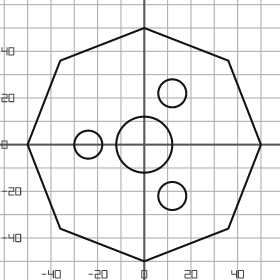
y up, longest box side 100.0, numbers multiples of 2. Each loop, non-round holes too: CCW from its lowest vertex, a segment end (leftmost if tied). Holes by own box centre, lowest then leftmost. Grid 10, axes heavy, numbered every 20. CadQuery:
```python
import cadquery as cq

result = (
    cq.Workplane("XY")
    .moveTo(0.0, -50.0)
    .lineTo(36.0, -36.0)
    .lineTo(50.0, 0.0)
    .lineTo(36.0, 36.0)
    .lineTo(0.0, 50.0)
    .lineTo(-36.0, 36.0)
    .lineTo(-50.0, 0.0)
    .lineTo(-36.0, -36.0)
    .close()
    .moveTo(12.0, -22.0)
    .circle(6.0)
    .moveTo(-24.0, 0.0)
    .circle(6.0)
    .moveTo(0.0, 0.0)
    .circle(12.0)
    .moveTo(12.0, 22.0)
    .circle(6.0)
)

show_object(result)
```